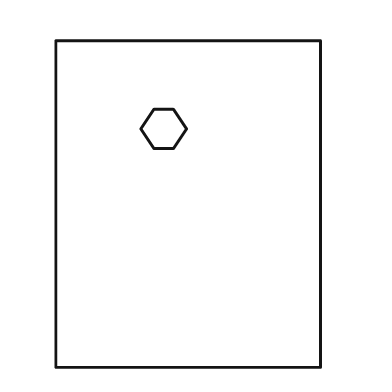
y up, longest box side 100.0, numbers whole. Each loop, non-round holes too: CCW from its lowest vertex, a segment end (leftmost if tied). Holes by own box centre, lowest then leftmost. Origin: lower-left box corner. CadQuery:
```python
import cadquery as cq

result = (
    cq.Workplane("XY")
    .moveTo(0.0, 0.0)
    .lineTo(81.0, 0.0)
    .lineTo(81.0, 100.0)
    .lineTo(0.0, 100.0)
    .close()
    .moveTo(30.0, 67.0)
    .lineTo(36.0, 67.0)
    .lineTo(40.0, 73.0)
    .lineTo(36.0, 79.0)
    .lineTo(30.0, 79.0)
    .lineTo(26.0, 73.0)
    .close()
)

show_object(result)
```